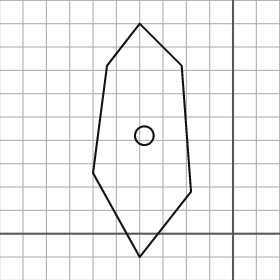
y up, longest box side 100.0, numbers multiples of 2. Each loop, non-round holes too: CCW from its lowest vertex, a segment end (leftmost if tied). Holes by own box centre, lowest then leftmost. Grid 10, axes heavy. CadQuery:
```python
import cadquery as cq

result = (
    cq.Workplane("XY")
    .moveTo(-40.0, -10.0)
    .lineTo(-18.0, 18.0)
    .lineTo(-22.0, 72.0)
    .lineTo(-40.0, 90.0)
    .lineTo(-54.0, 72.0)
    .lineTo(-60.0, 26.0)
    .close()
    .moveTo(-38.0, 42.0)
    .circle(4.0)
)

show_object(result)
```